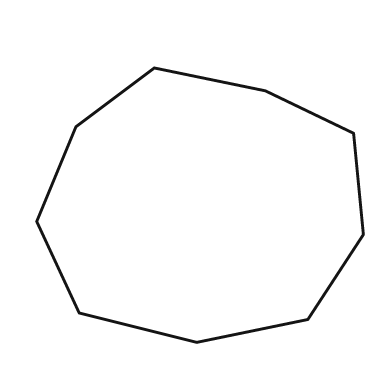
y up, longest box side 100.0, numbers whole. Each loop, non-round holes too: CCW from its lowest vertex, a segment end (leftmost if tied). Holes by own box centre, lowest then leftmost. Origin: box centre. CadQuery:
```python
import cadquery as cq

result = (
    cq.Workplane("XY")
    .moveTo(-1.0, -42.0)
    .lineTo(33.0, -35.0)
    .lineTo(50.0, -9.0)
    .lineTo(47.0, 22.0)
    .lineTo(20.0, 35.0)
    .lineTo(-14.0, 42.0)
    .lineTo(-38.0, 24.0)
    .lineTo(-50.0, -5.0)
    .lineTo(-37.0, -33.0)
    .close()
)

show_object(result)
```